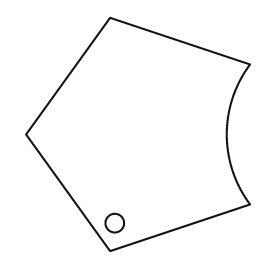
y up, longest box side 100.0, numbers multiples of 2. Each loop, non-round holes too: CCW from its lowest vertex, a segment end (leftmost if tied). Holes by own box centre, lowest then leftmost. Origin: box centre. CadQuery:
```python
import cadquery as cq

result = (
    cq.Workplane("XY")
    .moveTo(-12.0, -50.0)
    .lineTo(48.0, -30.0)
    .threePointArc((38.0, 0.0), (48.0, 30.0))
    .lineTo(-12.0, 50.0)
    .lineTo(-48.0, 0.0)
    .close()
    .moveTo(-10.0, -38.0)
    .circle(4.0)
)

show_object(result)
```